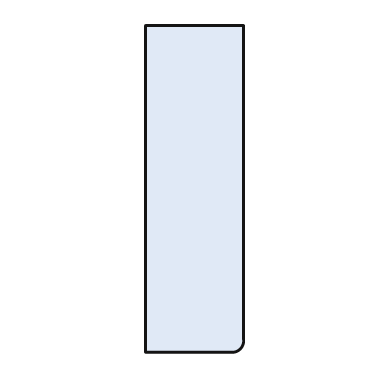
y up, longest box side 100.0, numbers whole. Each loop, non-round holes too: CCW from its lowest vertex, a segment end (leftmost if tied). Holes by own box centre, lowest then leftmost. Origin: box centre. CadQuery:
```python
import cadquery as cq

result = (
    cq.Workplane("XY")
    .moveTo(-15.0, -50.0)
    .lineTo(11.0, -50.0)
    .threePointArc((14.0, -49.0), (15.0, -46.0))
    .lineTo(15.0, 50.0)
    .lineTo(-15.0, 50.0)
    .close()
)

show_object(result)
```